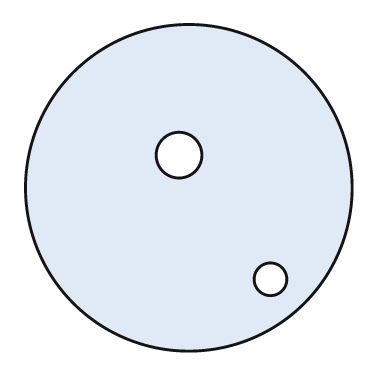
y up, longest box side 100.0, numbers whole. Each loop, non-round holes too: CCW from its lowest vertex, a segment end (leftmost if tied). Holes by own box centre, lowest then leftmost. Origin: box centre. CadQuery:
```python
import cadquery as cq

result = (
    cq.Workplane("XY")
    .moveTo(0.0, 0.0)
    .circle(50.0)
    .moveTo(25.0, -28.0)
    .circle(5.0)
    .moveTo(-3.0, 10.0)
    .circle(7.0)
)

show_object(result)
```